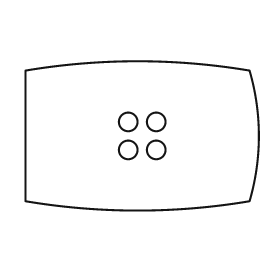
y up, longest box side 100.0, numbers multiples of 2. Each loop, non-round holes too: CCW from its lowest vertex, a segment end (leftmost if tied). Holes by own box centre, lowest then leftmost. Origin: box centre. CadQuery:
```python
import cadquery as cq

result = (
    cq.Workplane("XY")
    .moveTo(-50.0, -28.0)
    .threePointArc((-2.0, -32.0), (46.0, -28.0))
    .threePointArc((50.0, 0.0), (46.0, 28.0))
    .threePointArc((-2.0, 32.0), (-50.0, 28.0))
    .close()
    .moveTo(-6.0, -6.0)
    .circle(4.0)
    .moveTo(6.0, -6.0)
    .circle(4.0)
    .moveTo(-6.0, 6.0)
    .circle(4.0)
    .moveTo(6.0, 6.0)
    .circle(4.0)
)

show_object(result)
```